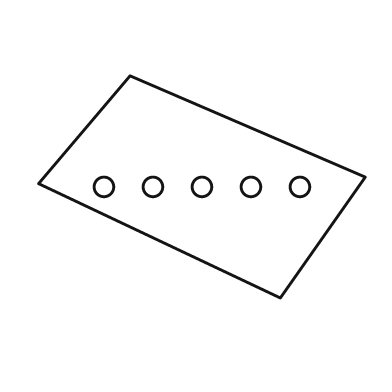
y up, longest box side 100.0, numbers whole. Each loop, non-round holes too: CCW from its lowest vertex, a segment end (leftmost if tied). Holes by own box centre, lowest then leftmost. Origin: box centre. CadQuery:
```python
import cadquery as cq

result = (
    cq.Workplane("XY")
    .moveTo(24.0, -34.0)
    .lineTo(50.0, 3.0)
    .lineTo(-22.0, 34.0)
    .lineTo(-50.0, 1.0)
    .close()
    .moveTo(-30.0, 0.0)
    .circle(3.0)
    .moveTo(-15.0, 0.0)
    .circle(3.0)
    .moveTo(0.0, 0.0)
    .circle(3.0)
    .moveTo(15.0, 0.0)
    .circle(3.0)
    .moveTo(30.0, 0.0)
    .circle(3.0)
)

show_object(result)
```